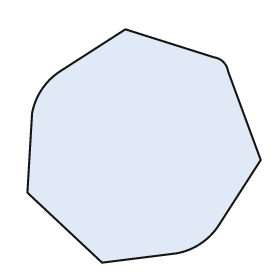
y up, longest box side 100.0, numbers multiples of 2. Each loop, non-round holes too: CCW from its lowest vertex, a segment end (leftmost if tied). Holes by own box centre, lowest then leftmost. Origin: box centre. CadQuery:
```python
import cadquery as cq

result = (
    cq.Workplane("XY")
    .moveTo(-18.0, -50.0)
    .lineTo(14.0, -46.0)
    .threePointArc((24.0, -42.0), (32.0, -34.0))
    .lineTo(50.0, -6.0)
    .lineTo(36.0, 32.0)
    .threePointArc((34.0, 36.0), (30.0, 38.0))
    .lineTo(-8.0, 50.0)
    .lineTo(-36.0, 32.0)
    .threePointArc((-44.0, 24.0), (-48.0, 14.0))
    .lineTo(-50.0, -20.0)
    .close()
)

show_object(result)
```